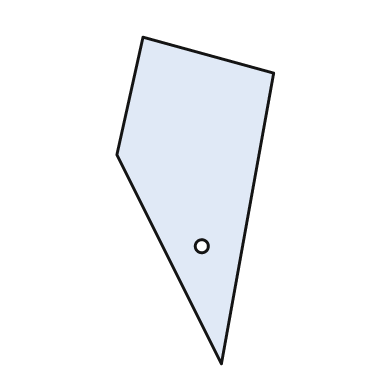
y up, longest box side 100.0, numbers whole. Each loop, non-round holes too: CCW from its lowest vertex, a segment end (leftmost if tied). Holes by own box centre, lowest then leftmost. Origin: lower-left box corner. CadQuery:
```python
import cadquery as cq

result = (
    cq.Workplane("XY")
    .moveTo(32.0, 0.0)
    .lineTo(48.0, 89.0)
    .lineTo(8.0, 100.0)
    .lineTo(0.0, 64.0)
    .close()
    .moveTo(26.0, 36.0)
    .circle(2.0)
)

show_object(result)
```